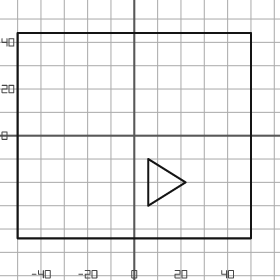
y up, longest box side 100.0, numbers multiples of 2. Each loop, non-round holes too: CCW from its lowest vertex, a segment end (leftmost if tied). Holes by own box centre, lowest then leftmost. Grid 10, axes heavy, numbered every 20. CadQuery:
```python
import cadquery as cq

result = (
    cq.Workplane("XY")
    .moveTo(-50.0, -44.0)
    .lineTo(50.0, -44.0)
    .lineTo(50.0, 44.0)
    .lineTo(-50.0, 44.0)
    .close()
    .moveTo(6.0, -30.0)
    .lineTo(22.0, -20.0)
    .lineTo(6.0, -10.0)
    .close()
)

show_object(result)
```